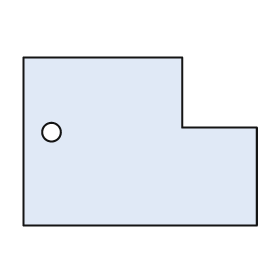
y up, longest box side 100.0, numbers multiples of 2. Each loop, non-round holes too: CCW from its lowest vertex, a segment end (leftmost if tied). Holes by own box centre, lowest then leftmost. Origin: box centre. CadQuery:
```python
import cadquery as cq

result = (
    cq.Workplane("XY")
    .moveTo(-50.0, -36.0)
    .lineTo(50.0, -36.0)
    .lineTo(50.0, 6.0)
    .lineTo(18.0, 6.0)
    .lineTo(18.0, 36.0)
    .lineTo(-50.0, 36.0)
    .close()
    .moveTo(-38.0, 4.0)
    .circle(4.0)
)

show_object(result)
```